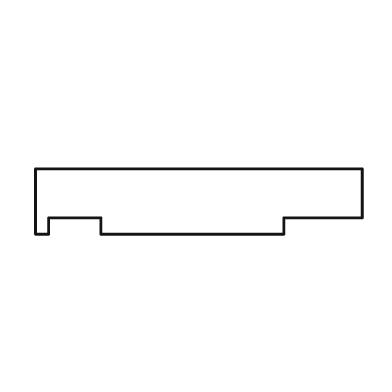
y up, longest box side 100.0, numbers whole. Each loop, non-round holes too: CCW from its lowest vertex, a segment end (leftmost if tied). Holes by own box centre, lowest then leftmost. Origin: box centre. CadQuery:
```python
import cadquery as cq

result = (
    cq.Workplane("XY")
    .moveTo(-50.0, -10.0)
    .lineTo(-46.0, -10.0)
    .lineTo(-46.0, -5.0)
    .lineTo(-30.0, -5.0)
    .lineTo(-30.0, -10.0)
    .lineTo(26.0, -10.0)
    .lineTo(26.0, -5.0)
    .lineTo(50.0, -5.0)
    .lineTo(50.0, 10.0)
    .lineTo(-50.0, 10.0)
    .close()
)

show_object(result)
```